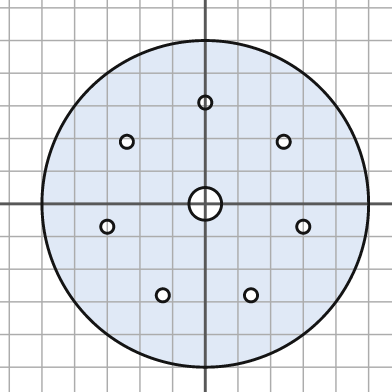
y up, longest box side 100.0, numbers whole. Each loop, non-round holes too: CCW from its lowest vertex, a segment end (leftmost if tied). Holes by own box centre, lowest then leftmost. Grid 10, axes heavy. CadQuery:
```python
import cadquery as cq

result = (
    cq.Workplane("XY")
    .moveTo(0.0, 0.0)
    .circle(50.0)
    .moveTo(-13.0, -28.0)
    .circle(2.0)
    .moveTo(14.0, -28.0)
    .circle(2.0)
    .moveTo(-30.0, -7.0)
    .circle(2.0)
    .moveTo(30.0, -7.0)
    .circle(2.0)
    .moveTo(0.0, 0.0)
    .circle(5.0)
    .moveTo(-24.0, 19.0)
    .circle(2.0)
    .moveTo(24.0, 19.0)
    .circle(2.0)
    .moveTo(0.0, 31.0)
    .circle(2.0)
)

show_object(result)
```